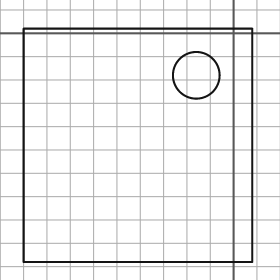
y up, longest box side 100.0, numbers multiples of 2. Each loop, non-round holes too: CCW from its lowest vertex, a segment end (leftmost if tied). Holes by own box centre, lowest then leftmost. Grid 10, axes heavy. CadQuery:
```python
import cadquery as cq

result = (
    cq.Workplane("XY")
    .moveTo(-90.0, -98.0)
    .lineTo(8.0, -98.0)
    .lineTo(8.0, 2.0)
    .lineTo(-90.0, 2.0)
    .close()
    .moveTo(-16.0, -18.0)
    .circle(10.0)
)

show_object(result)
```